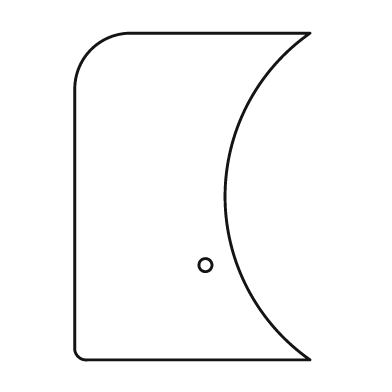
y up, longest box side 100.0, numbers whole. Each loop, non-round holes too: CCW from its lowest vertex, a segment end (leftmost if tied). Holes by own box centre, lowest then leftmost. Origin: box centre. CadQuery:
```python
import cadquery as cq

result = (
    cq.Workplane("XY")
    .moveTo(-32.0, -50.0)
    .lineTo(36.0, -50.0)
    .threePointArc((10.0, 0.0), (36.0, 50.0))
    .lineTo(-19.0, 50.0)
    .threePointArc((-31.0, 45.0), (-36.0, 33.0))
    .lineTo(-36.0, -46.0)
    .threePointArc((-35.0, -49.0), (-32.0, -50.0))
    .close()
    .moveTo(4.0, -21.0)
    .circle(2.0)
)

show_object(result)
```